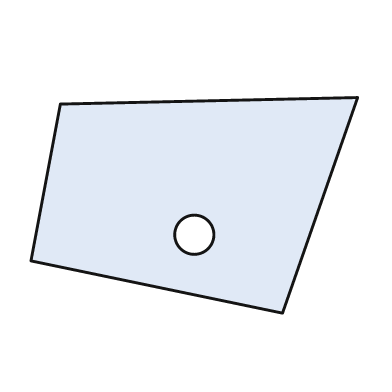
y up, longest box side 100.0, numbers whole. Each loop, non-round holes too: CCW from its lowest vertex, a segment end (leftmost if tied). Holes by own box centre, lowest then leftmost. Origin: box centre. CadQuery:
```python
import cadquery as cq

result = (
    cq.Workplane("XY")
    .moveTo(27.0, -33.0)
    .lineTo(50.0, 33.0)
    .lineTo(-41.0, 31.0)
    .lineTo(-50.0, -17.0)
    .close()
    .moveTo(0.0, -9.0)
    .circle(6.0)
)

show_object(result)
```